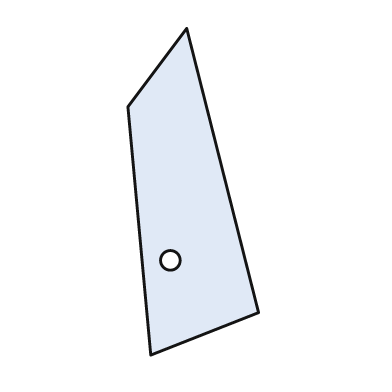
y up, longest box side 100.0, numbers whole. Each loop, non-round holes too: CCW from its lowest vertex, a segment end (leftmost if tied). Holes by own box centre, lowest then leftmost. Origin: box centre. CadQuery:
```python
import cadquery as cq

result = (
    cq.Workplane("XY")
    .moveTo(-13.0, -50.0)
    .lineTo(20.0, -37.0)
    .lineTo(-2.0, 50.0)
    .lineTo(-20.0, 26.0)
    .close()
    .moveTo(-7.0, -21.0)
    .circle(3.0)
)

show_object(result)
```